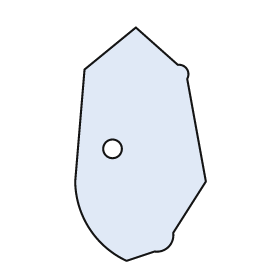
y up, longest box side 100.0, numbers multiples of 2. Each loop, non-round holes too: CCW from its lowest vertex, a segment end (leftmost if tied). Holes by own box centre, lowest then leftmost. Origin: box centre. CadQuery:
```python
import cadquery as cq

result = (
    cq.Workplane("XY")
    .moveTo(-6.0, -50.0)
    .lineTo(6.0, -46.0)
    .threePointArc((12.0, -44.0), (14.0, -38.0))
    .lineTo(28.0, -16.0)
    .lineTo(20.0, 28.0)
    .threePointArc((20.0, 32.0), (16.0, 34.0))
    .lineTo(-2.0, 50.0)
    .lineTo(-24.0, 32.0)
    .lineTo(-28.0, -16.0)
    .threePointArc((-22.0, -36.0), (-6.0, -50.0))
    .close()
    .moveTo(-12.0, -2.0)
    .circle(4.0)
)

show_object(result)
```